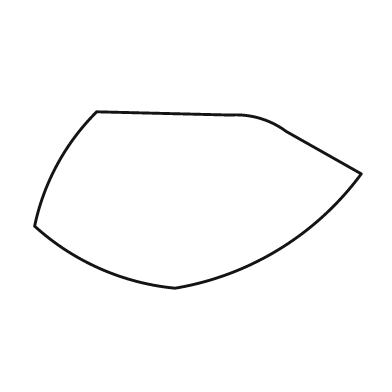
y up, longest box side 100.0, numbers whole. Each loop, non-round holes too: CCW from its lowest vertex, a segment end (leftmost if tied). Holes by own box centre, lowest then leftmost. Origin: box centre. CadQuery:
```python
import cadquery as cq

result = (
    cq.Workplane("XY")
    .moveTo(-7.0, -27.0)
    .threePointArc((25.0, -15.0), (50.0, 8.0))
    .lineTo(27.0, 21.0)
    .threePointArc((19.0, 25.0), (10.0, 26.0))
    .lineTo(-31.0, 27.0)
    .threePointArc((-43.0, 11.0), (-50.0, -8.0))
    .threePointArc((-30.0, -21.0), (-7.0, -27.0))
    .close()
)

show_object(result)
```